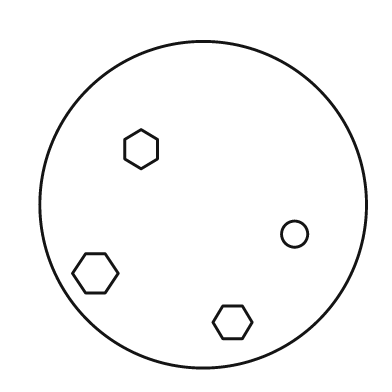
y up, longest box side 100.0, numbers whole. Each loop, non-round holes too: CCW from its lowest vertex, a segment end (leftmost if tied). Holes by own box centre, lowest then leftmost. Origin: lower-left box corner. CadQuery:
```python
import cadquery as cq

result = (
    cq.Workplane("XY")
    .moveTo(50.0, 50.0)
    .circle(50.0)
    .moveTo(56.0, 9.0)
    .lineTo(62.0, 9.0)
    .lineTo(65.0, 14.0)
    .lineTo(62.0, 19.0)
    .lineTo(56.0, 19.0)
    .lineTo(53.0, 14.0)
    .close()
    .moveTo(14.0, 23.0)
    .lineTo(20.0, 23.0)
    .lineTo(24.0, 29.0)
    .lineTo(20.0, 35.0)
    .lineTo(14.0, 35.0)
    .lineTo(10.0, 29.0)
    .close()
    .moveTo(78.0, 41.0)
    .circle(4.0)
    .moveTo(31.0, 61.0)
    .lineTo(36.0, 64.0)
    .lineTo(36.0, 70.0)
    .lineTo(31.0, 73.0)
    .lineTo(26.0, 70.0)
    .lineTo(26.0, 64.0)
    .close()
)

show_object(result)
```